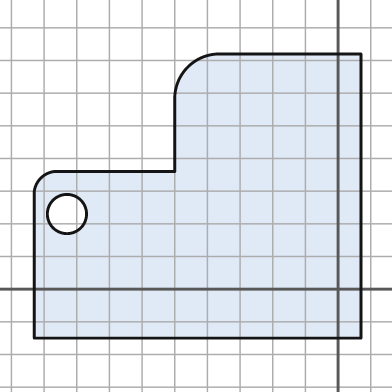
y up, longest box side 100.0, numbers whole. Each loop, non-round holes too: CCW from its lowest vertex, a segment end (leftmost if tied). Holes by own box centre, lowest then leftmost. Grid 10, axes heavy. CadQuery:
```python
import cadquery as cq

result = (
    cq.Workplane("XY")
    .moveTo(-93.0, -15.0)
    .lineTo(7.0, -15.0)
    .lineTo(7.0, 72.0)
    .lineTo(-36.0, 72.0)
    .threePointArc((-46.0, 68.0), (-50.0, 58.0))
    .lineTo(-50.0, 36.0)
    .lineTo(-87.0, 36.0)
    .threePointArc((-91.0, 34.0), (-93.0, 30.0))
    .close()
    .moveTo(-83.0, 23.0)
    .circle(6.0)
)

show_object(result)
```